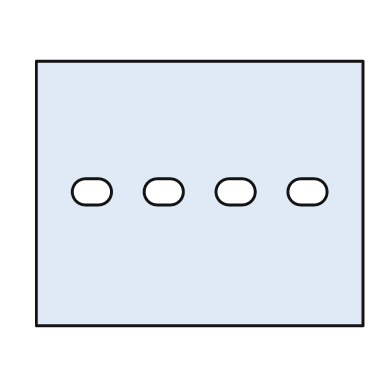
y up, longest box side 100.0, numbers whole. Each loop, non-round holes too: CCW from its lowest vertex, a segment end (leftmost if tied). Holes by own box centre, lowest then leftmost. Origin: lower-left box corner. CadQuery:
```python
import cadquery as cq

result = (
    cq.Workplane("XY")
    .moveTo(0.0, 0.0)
    .lineTo(100.0, 0.0)
    .lineTo(100.0, 81.0)
    .lineTo(0.0, 81.0)
    .close()
    .moveTo(15.0, 37.0)
    .lineTo(19.0, 37.0)
    .threePointArc((23.0, 41.0), (19.0, 45.0))
    .lineTo(15.0, 45.0)
    .threePointArc((11.0, 41.0), (15.0, 37.0))
    .close()
    .moveTo(37.0, 37.0)
    .lineTo(41.0, 37.0)
    .threePointArc((45.0, 41.0), (41.0, 45.0))
    .lineTo(37.0, 45.0)
    .threePointArc((33.0, 41.0), (37.0, 37.0))
    .close()
    .moveTo(59.0, 37.0)
    .lineTo(63.0, 37.0)
    .threePointArc((67.0, 41.0), (63.0, 45.0))
    .lineTo(59.0, 45.0)
    .threePointArc((55.0, 41.0), (59.0, 37.0))
    .close()
    .moveTo(81.0, 37.0)
    .lineTo(85.0, 37.0)
    .threePointArc((89.0, 41.0), (85.0, 45.0))
    .lineTo(81.0, 45.0)
    .threePointArc((77.0, 41.0), (81.0, 37.0))
    .close()
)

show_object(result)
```